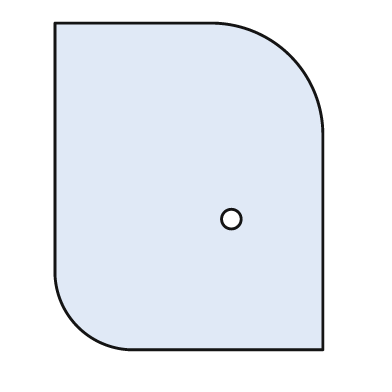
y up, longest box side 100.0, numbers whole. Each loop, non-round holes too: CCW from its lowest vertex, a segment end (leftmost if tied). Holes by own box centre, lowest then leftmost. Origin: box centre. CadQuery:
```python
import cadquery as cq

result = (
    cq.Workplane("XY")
    .moveTo(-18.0, -50.0)
    .lineTo(41.0, -50.0)
    .lineTo(41.0, 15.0)
    .threePointArc((31.0, 40.0), (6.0, 50.0))
    .lineTo(-41.0, 50.0)
    .lineTo(-41.0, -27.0)
    .threePointArc((-34.0, -43.0), (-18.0, -50.0))
    .close()
    .moveTo(13.0, -10.0)
    .circle(3.0)
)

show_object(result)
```